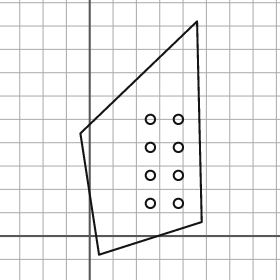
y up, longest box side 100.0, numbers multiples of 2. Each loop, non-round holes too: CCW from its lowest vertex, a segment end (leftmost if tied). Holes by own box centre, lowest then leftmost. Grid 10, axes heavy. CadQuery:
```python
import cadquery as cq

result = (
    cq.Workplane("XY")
    .moveTo(4.0, -8.0)
    .lineTo(48.0, 6.0)
    .lineTo(46.0, 92.0)
    .lineTo(-4.0, 44.0)
    .close()
    .moveTo(26.0, 14.0)
    .circle(2.0)
    .moveTo(38.0, 14.0)
    .circle(2.0)
    .moveTo(26.0, 26.0)
    .circle(2.0)
    .moveTo(38.0, 26.0)
    .circle(2.0)
    .moveTo(26.0, 38.0)
    .circle(2.0)
    .moveTo(38.0, 38.0)
    .circle(2.0)
    .moveTo(26.0, 50.0)
    .circle(2.0)
    .moveTo(38.0, 50.0)
    .circle(2.0)
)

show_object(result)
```